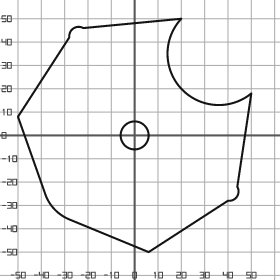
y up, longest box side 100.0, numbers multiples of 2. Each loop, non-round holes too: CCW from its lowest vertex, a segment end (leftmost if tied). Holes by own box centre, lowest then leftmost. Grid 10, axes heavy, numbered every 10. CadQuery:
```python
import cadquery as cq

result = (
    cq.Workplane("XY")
    .moveTo(6.0, -50.0)
    .lineTo(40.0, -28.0)
    .threePointArc((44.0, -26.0), (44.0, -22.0))
    .lineTo(50.0, 18.0)
    .threePointArc((20.0, 20.0), (20.0, 50.0))
    .lineTo(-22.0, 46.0)
    .threePointArc((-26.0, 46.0), (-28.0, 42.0))
    .lineTo(-50.0, 8.0)
    .lineTo(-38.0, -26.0)
    .threePointArc((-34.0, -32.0), (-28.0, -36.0))
    .close()
    .moveTo(0.0, 0.0)
    .circle(6.0)
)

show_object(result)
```